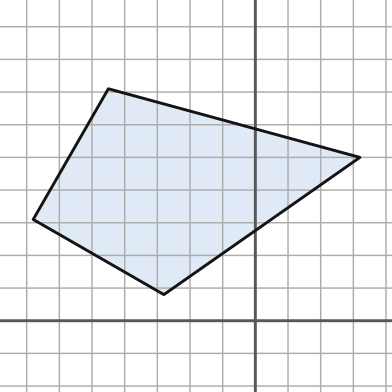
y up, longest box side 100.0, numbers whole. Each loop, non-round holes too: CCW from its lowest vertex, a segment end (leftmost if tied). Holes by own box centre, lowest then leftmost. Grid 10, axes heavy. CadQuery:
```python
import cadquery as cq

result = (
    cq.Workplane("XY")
    .moveTo(-28.0, 8.0)
    .lineTo(32.0, 50.0)
    .lineTo(-45.0, 71.0)
    .lineTo(-68.0, 31.0)
    .close()
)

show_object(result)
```